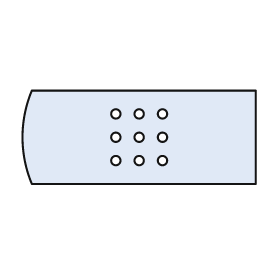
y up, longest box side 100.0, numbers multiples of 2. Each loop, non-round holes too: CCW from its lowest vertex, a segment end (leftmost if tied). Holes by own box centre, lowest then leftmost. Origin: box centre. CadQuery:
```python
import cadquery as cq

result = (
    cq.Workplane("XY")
    .moveTo(-46.0, -20.0)
    .lineTo(50.0, -20.0)
    .lineTo(50.0, 20.0)
    .lineTo(-46.0, 20.0)
    .threePointArc((-50.0, 0.0), (-46.0, -20.0))
    .close()
    .moveTo(-10.0, -10.0)
    .circle(2.0)
    .moveTo(0.0, -10.0)
    .circle(2.0)
    .moveTo(10.0, -10.0)
    .circle(2.0)
    .moveTo(-10.0, 0.0)
    .circle(2.0)
    .moveTo(0.0, 0.0)
    .circle(2.0)
    .moveTo(10.0, 0.0)
    .circle(2.0)
    .moveTo(-10.0, 10.0)
    .circle(2.0)
    .moveTo(0.0, 10.0)
    .circle(2.0)
    .moveTo(10.0, 10.0)
    .circle(2.0)
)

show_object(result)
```